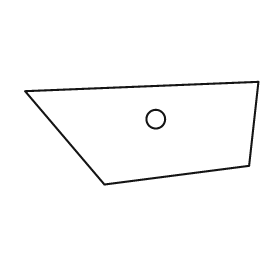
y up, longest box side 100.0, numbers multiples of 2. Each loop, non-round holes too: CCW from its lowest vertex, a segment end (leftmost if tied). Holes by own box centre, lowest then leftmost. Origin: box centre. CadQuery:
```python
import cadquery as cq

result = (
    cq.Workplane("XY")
    .moveTo(-16.0, -22.0)
    .lineTo(46.0, -14.0)
    .lineTo(50.0, 22.0)
    .lineTo(-50.0, 18.0)
    .close()
    .moveTo(6.0, 6.0)
    .circle(4.0)
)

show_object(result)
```